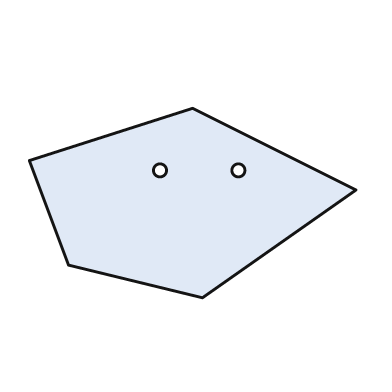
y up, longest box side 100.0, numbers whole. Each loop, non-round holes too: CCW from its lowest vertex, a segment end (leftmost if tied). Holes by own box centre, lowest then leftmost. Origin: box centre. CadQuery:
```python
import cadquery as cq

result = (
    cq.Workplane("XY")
    .moveTo(3.0, -29.0)
    .lineTo(50.0, 4.0)
    .lineTo(0.0, 29.0)
    .lineTo(-50.0, 13.0)
    .lineTo(-38.0, -19.0)
    .close()
    .moveTo(-10.0, 10.0)
    .circle(2.0)
    .moveTo(14.0, 10.0)
    .circle(2.0)
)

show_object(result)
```